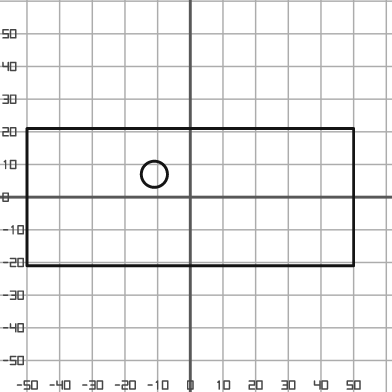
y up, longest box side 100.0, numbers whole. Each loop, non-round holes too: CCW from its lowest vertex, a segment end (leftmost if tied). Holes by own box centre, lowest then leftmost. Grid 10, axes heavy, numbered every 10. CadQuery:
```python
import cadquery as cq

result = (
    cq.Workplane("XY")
    .moveTo(-50.0, -21.0)
    .lineTo(50.0, -21.0)
    .lineTo(50.0, 21.0)
    .lineTo(-50.0, 21.0)
    .close()
    .moveTo(-11.0, 7.0)
    .circle(4.0)
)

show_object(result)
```